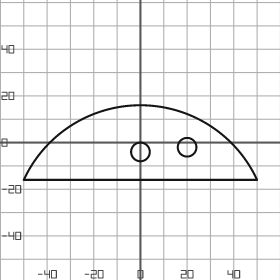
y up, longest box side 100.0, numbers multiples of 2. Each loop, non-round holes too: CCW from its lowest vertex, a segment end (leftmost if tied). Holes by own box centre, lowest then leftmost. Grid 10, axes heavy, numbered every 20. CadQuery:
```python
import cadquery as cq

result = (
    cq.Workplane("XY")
    .moveTo(-50.0, -16.0)
    .lineTo(50.0, -16.0)
    .threePointArc((0.0, 16.0), (-50.0, -16.0))
    .close()
    .moveTo(0.0, -4.0)
    .circle(4.0)
    .moveTo(20.0, -2.0)
    .circle(4.0)
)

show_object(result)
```